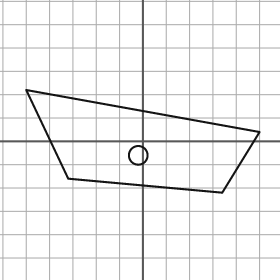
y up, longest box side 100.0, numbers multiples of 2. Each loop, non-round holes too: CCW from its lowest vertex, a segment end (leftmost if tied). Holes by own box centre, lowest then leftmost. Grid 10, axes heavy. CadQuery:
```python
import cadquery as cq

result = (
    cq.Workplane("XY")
    .moveTo(34.0, -22.0)
    .lineTo(50.0, 4.0)
    .lineTo(-50.0, 22.0)
    .lineTo(-32.0, -16.0)
    .close()
    .moveTo(-2.0, -6.0)
    .circle(4.0)
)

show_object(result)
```